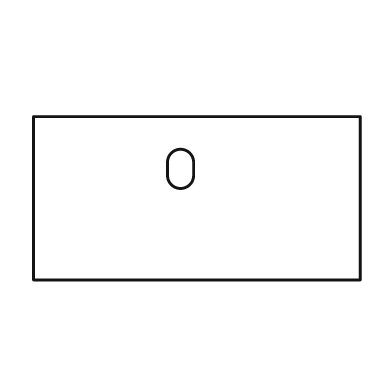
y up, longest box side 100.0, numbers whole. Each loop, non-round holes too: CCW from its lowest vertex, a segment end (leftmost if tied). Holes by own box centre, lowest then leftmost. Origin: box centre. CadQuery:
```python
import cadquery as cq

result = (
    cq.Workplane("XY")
    .moveTo(-50.0, -25.0)
    .lineTo(50.0, -25.0)
    .lineTo(50.0, 25.0)
    .lineTo(-50.0, 25.0)
    .close()
    .moveTo(-9.0, 7.0)
    .threePointArc((-5.0, 3.0), (-1.0, 7.0))
    .lineTo(-1.0, 11.0)
    .threePointArc((-5.0, 15.0), (-9.0, 11.0))
    .close()
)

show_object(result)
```